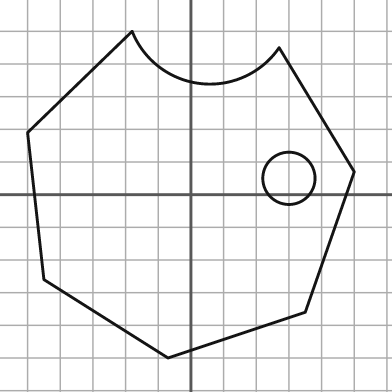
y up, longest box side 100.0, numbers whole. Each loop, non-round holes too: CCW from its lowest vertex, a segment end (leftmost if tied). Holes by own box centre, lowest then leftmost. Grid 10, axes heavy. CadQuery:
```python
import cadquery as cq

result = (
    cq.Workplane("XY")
    .moveTo(-7.0, -50.0)
    .lineTo(35.0, -36.0)
    .lineTo(50.0, 7.0)
    .lineTo(27.0, 45.0)
    .threePointArc((3.0, 34.0), (-18.0, 50.0))
    .lineTo(-50.0, 19.0)
    .lineTo(-45.0, -26.0)
    .close()
    .moveTo(30.0, 5.0)
    .circle(8.0)
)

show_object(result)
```